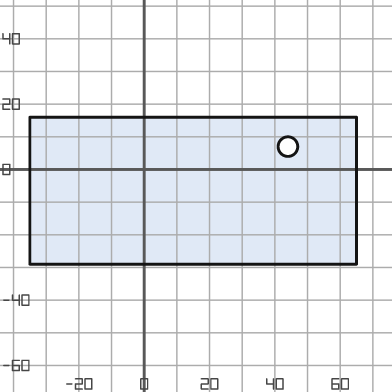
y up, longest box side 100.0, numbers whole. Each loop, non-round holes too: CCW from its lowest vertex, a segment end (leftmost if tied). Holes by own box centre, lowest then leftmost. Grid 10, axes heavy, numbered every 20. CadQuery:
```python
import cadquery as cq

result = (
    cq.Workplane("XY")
    .moveTo(-35.0, -29.0)
    .lineTo(65.0, -29.0)
    .lineTo(65.0, 16.0)
    .lineTo(-35.0, 16.0)
    .close()
    .moveTo(44.0, 7.0)
    .circle(3.0)
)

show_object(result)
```